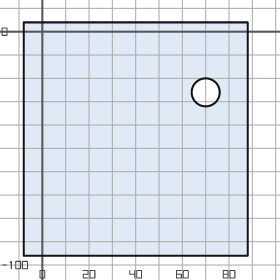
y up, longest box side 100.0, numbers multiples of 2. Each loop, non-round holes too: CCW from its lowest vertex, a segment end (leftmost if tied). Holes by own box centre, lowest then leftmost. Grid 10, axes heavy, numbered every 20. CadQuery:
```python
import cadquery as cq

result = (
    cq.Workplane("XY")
    .moveTo(-8.0, -96.0)
    .lineTo(88.0, -96.0)
    .lineTo(88.0, 4.0)
    .lineTo(-8.0, 4.0)
    .close()
    .moveTo(70.0, -26.0)
    .circle(6.0)
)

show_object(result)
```